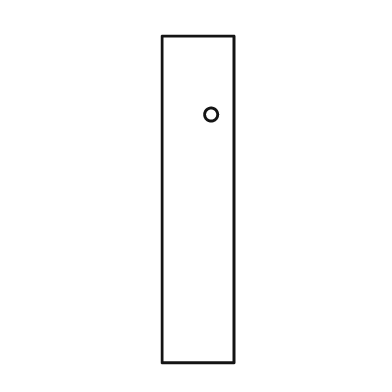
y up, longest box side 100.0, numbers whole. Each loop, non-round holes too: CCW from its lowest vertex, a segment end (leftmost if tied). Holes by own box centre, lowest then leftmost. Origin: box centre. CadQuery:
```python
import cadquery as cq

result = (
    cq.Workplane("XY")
    .moveTo(-11.0, -50.0)
    .lineTo(11.0, -50.0)
    .lineTo(11.0, 50.0)
    .lineTo(-11.0, 50.0)
    .close()
    .moveTo(4.0, 26.0)
    .circle(2.0)
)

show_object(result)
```